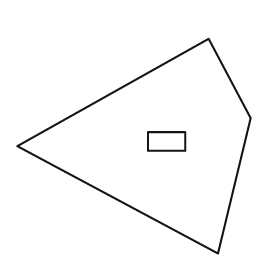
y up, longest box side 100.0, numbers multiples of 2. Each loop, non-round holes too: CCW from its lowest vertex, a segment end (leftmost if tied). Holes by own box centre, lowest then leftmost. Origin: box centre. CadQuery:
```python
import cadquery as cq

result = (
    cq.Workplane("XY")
    .moveTo(36.0, -46.0)
    .lineTo(50.0, 12.0)
    .lineTo(32.0, 46.0)
    .lineTo(-50.0, 0.0)
    .close()
    .moveTo(6.0, -2.0)
    .lineTo(22.0, -2.0)
    .lineTo(22.0, 6.0)
    .lineTo(6.0, 6.0)
    .close()
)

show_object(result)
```